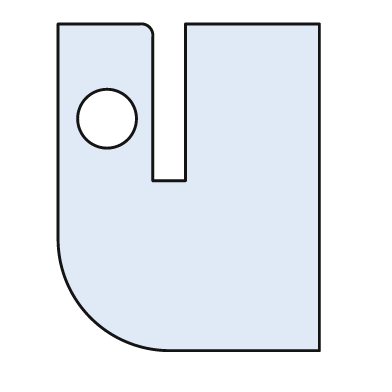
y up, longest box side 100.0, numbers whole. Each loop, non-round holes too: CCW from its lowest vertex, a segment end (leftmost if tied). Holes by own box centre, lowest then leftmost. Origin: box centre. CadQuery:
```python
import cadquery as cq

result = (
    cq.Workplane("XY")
    .moveTo(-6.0, -50.0)
    .lineTo(40.0, -50.0)
    .lineTo(40.0, 50.0)
    .lineTo(-1.0, 50.0)
    .lineTo(-1.0, 2.0)
    .lineTo(-11.0, 2.0)
    .lineTo(-11.0, 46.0)
    .threePointArc((-12.0, 49.0), (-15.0, 50.0))
    .lineTo(-40.0, 50.0)
    .lineTo(-40.0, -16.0)
    .threePointArc((-30.0, -40.0), (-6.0, -50.0))
    .close()
    .moveTo(-25.0, 21.0)
    .circle(9.0)
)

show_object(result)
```